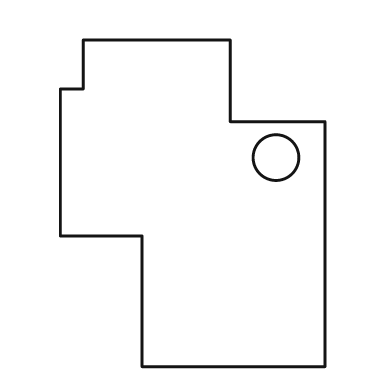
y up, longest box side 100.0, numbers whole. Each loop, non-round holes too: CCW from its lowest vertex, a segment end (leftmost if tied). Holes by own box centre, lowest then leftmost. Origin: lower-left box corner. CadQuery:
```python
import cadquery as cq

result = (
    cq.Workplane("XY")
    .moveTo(25.0, 0.0)
    .lineTo(81.0, 0.0)
    .lineTo(81.0, 75.0)
    .lineTo(52.0, 75.0)
    .lineTo(52.0, 100.0)
    .lineTo(7.0, 100.0)
    .lineTo(7.0, 85.0)
    .lineTo(0.0, 85.0)
    .lineTo(0.0, 40.0)
    .lineTo(25.0, 40.0)
    .close()
    .moveTo(66.0, 64.0)
    .circle(7.0)
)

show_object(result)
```